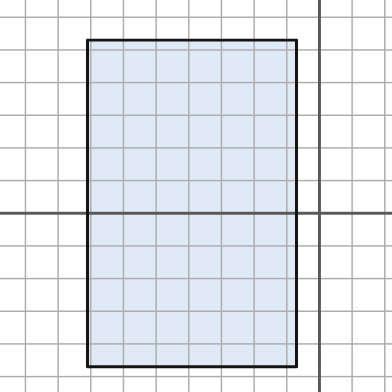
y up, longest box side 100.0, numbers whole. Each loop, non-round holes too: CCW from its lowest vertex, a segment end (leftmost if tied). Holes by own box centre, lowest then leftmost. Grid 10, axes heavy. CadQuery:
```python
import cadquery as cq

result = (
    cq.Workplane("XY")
    .moveTo(-71.0, -47.0)
    .lineTo(-7.0, -47.0)
    .lineTo(-7.0, 53.0)
    .lineTo(-71.0, 53.0)
    .close()
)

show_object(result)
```